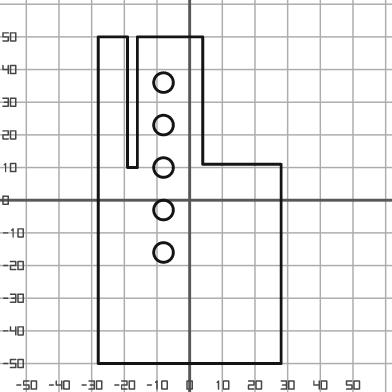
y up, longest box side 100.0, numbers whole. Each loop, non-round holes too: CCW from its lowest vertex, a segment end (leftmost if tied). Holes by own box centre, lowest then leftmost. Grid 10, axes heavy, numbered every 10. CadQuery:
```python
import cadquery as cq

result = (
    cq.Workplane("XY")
    .moveTo(-28.0, -50.0)
    .lineTo(28.0, -50.0)
    .lineTo(28.0, 11.0)
    .lineTo(4.0, 11.0)
    .lineTo(4.0, 50.0)
    .lineTo(-16.0, 50.0)
    .lineTo(-16.0, 10.0)
    .lineTo(-19.0, 10.0)
    .lineTo(-19.0, 50.0)
    .lineTo(-28.0, 50.0)
    .close()
    .moveTo(-8.0, -16.0)
    .circle(3.0)
    .moveTo(-8.0, -3.0)
    .circle(3.0)
    .moveTo(-8.0, 10.0)
    .circle(3.0)
    .moveTo(-8.0, 23.0)
    .circle(3.0)
    .moveTo(-8.0, 36.0)
    .circle(3.0)
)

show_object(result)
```